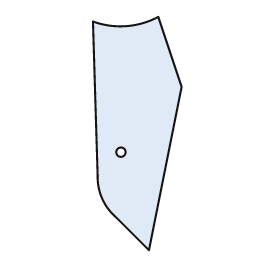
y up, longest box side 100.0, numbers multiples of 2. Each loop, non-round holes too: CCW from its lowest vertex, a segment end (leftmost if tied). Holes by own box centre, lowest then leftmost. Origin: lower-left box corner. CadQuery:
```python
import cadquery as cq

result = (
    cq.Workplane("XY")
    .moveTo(24.0, 0.0)
    .lineTo(38.0, 70.0)
    .lineTo(28.0, 100.0)
    .threePointArc((14.0, 96.0), (0.0, 98.0))
    .lineTo(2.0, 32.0)
    .threePointArc((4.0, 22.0), (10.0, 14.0))
    .close()
    .moveTo(12.0, 42.0)
    .circle(2.0)
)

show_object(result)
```